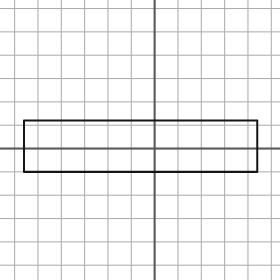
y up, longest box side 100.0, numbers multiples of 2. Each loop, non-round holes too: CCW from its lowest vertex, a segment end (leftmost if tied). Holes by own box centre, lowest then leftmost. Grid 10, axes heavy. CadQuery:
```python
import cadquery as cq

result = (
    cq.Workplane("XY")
    .moveTo(-56.0, -10.0)
    .lineTo(44.0, -10.0)
    .lineTo(44.0, 12.0)
    .lineTo(-56.0, 12.0)
    .close()
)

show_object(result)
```